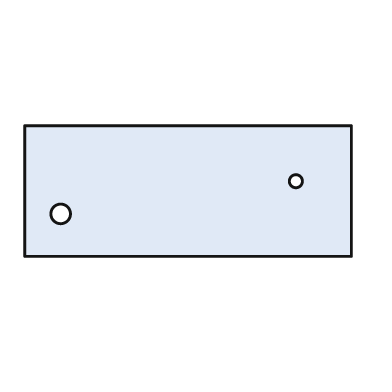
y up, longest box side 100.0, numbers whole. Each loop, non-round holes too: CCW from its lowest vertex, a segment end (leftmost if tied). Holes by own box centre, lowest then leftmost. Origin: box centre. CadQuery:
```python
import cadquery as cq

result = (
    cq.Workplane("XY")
    .moveTo(-50.0, -20.0)
    .lineTo(50.0, -20.0)
    .lineTo(50.0, 20.0)
    .lineTo(-50.0, 20.0)
    .close()
    .moveTo(-39.0, -7.0)
    .circle(3.0)
    .moveTo(33.0, 3.0)
    .circle(2.0)
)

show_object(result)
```